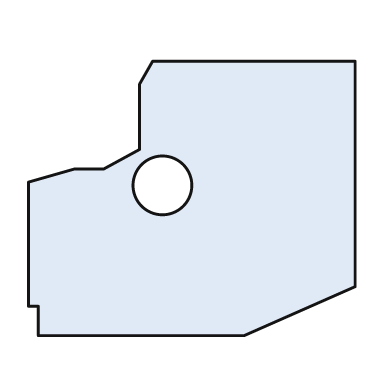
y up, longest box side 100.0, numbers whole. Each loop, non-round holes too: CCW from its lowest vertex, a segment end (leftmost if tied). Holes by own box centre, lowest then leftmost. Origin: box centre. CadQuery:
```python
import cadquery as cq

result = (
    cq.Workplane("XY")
    .moveTo(-47.0, -42.0)
    .lineTo(16.0, -42.0)
    .lineTo(50.0, -27.0)
    .lineTo(50.0, 42.0)
    .lineTo(-12.0, 42.0)
    .lineTo(-16.0, 35.0)
    .lineTo(-16.0, 15.0)
    .lineTo(-27.0, 9.0)
    .lineTo(-36.0, 9.0)
    .lineTo(-50.0, 5.0)
    .lineTo(-50.0, -33.0)
    .lineTo(-47.0, -33.0)
    .close()
    .moveTo(-9.0, 4.0)
    .circle(9.0)
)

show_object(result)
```